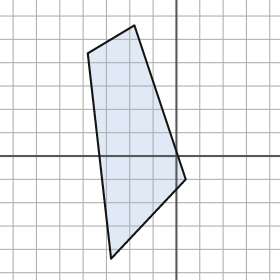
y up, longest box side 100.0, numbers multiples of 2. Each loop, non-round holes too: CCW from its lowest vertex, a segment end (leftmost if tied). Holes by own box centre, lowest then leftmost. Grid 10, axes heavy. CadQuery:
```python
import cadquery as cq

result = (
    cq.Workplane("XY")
    .moveTo(-28.0, -44.0)
    .lineTo(4.0, -10.0)
    .lineTo(-18.0, 56.0)
    .lineTo(-38.0, 44.0)
    .close()
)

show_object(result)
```